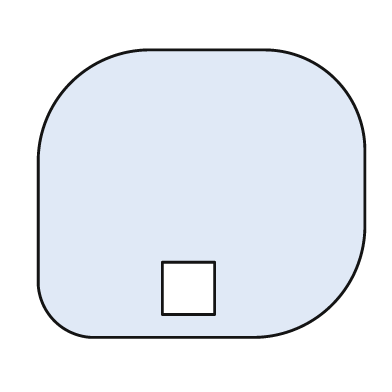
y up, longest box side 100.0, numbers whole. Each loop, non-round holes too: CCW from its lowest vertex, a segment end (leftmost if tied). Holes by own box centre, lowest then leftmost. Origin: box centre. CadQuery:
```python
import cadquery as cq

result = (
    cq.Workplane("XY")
    .moveTo(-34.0, -44.0)
    .lineTo(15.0, -44.0)
    .threePointArc((40.0, -34.0), (50.0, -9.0))
    .lineTo(50.0, 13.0)
    .threePointArc((41.0, 35.0), (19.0, 44.0))
    .lineTo(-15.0, 44.0)
    .threePointArc((-40.0, 34.0), (-50.0, 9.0))
    .lineTo(-50.0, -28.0)
    .threePointArc((-45.0, -39.0), (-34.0, -44.0))
    .close()
    .moveTo(-12.0, -37.0)
    .lineTo(4.0, -37.0)
    .lineTo(4.0, -21.0)
    .lineTo(-12.0, -21.0)
    .close()
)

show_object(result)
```